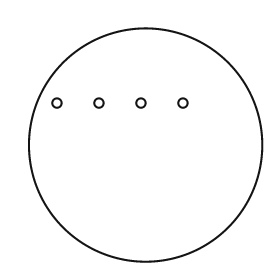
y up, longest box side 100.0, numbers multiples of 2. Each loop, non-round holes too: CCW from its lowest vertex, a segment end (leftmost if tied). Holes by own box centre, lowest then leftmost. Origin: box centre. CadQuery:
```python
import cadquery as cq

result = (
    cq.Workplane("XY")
    .moveTo(0.0, 0.0)
    .circle(50.0)
    .moveTo(-38.0, 18.0)
    .circle(2.0)
    .moveTo(-20.0, 18.0)
    .circle(2.0)
    .moveTo(-2.0, 18.0)
    .circle(2.0)
    .moveTo(16.0, 18.0)
    .circle(2.0)
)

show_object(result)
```